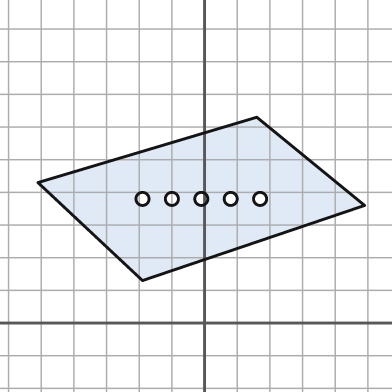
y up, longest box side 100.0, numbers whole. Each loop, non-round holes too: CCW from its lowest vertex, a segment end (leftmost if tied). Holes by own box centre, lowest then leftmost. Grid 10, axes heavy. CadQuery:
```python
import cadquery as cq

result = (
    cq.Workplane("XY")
    .moveTo(-19.0, 13.0)
    .lineTo(49.0, 36.0)
    .lineTo(16.0, 63.0)
    .lineTo(-51.0, 43.0)
    .close()
    .moveTo(-19.0, 38.0)
    .circle(2.0)
    .moveTo(-10.0, 38.0)
    .circle(2.0)
    .moveTo(-1.0, 38.0)
    .circle(2.0)
    .moveTo(8.0, 38.0)
    .circle(2.0)
    .moveTo(17.0, 38.0)
    .circle(2.0)
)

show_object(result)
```